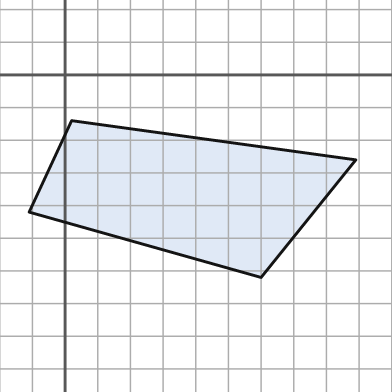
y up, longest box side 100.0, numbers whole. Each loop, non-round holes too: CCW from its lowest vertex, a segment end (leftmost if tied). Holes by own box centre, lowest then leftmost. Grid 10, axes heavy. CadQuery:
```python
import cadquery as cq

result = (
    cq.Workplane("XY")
    .moveTo(60.0, -62.0)
    .lineTo(89.0, -26.0)
    .lineTo(2.0, -14.0)
    .lineTo(-11.0, -42.0)
    .close()
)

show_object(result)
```